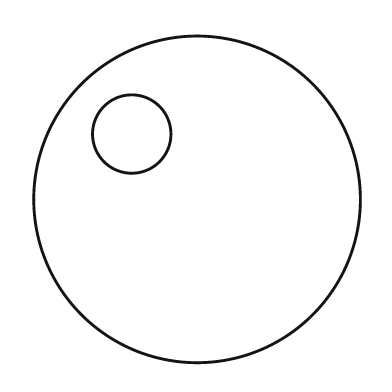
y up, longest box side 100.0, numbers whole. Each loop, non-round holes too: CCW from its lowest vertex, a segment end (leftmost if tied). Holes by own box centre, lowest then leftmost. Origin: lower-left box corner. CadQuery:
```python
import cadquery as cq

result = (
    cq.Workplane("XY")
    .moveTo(50.0, 50.0)
    .circle(50.0)
    .moveTo(30.0, 70.0)
    .circle(12.0)
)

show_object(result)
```